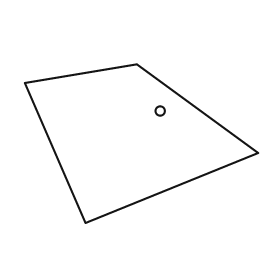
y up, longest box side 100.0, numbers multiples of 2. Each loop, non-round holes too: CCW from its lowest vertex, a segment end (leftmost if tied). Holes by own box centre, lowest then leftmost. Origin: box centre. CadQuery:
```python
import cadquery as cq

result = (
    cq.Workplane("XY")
    .moveTo(-24.0, -34.0)
    .lineTo(50.0, -4.0)
    .lineTo(-2.0, 34.0)
    .lineTo(-50.0, 26.0)
    .close()
    .moveTo(8.0, 14.0)
    .circle(2.0)
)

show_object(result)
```